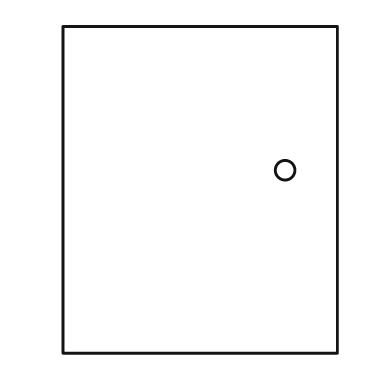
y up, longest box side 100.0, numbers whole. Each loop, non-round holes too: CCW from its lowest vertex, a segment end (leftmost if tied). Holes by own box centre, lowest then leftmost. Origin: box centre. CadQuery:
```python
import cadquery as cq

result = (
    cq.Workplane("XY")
    .moveTo(-42.0, -50.0)
    .lineTo(42.0, -50.0)
    .lineTo(42.0, 50.0)
    .lineTo(-42.0, 50.0)
    .close()
    .moveTo(26.0, 6.0)
    .circle(3.0)
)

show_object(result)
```